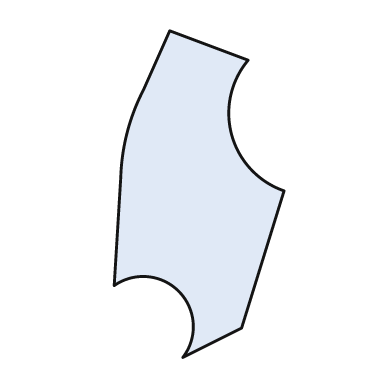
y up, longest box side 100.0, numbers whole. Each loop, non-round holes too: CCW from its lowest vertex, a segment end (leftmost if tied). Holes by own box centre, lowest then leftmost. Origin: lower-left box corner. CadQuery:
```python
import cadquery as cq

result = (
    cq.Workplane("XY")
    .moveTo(21.0, 0.0)
    .lineTo(39.0, 9.0)
    .lineTo(52.0, 51.0)
    .threePointArc((36.0, 68.0), (41.0, 91.0))
    .lineTo(17.0, 100.0)
    .lineTo(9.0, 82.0)
    .threePointArc((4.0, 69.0), (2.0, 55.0))
    .lineTo(0.0, 22.0)
    .threePointArc((20.0, 20.0), (21.0, 0.0))
    .close()
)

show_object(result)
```